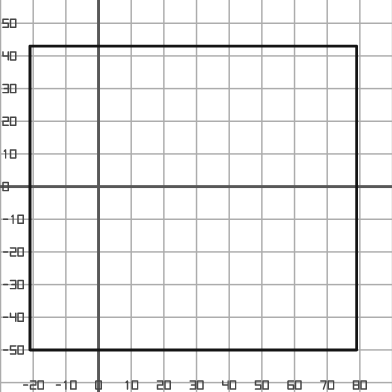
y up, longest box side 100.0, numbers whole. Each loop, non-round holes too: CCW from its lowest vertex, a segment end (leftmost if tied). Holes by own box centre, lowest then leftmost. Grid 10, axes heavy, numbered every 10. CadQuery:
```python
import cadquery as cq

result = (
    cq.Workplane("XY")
    .moveTo(-21.0, -50.0)
    .lineTo(79.0, -50.0)
    .lineTo(79.0, 43.0)
    .lineTo(-21.0, 43.0)
    .close()
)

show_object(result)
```